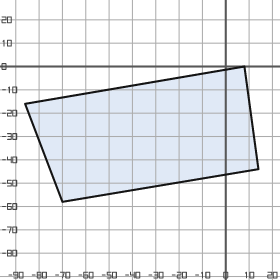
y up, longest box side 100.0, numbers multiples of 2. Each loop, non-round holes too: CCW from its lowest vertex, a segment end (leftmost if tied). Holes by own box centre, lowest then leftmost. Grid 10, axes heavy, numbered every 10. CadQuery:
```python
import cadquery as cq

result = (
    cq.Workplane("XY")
    .moveTo(-70.0, -58.0)
    .lineTo(14.0, -44.0)
    .lineTo(8.0, 0.0)
    .lineTo(-86.0, -16.0)
    .close()
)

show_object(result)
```